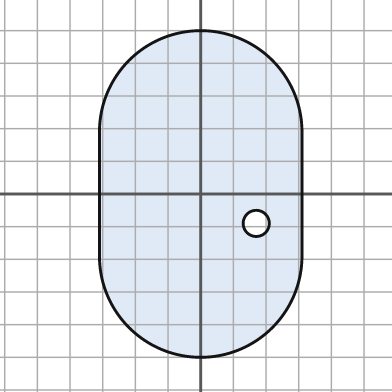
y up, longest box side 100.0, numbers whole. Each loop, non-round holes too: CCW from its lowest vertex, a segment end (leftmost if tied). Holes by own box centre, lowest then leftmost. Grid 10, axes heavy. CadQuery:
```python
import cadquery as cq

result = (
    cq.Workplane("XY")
    .moveTo(-31.0, -19.0)
    .threePointArc((0.0, -50.0), (31.0, -19.0))
    .lineTo(31.0, 19.0)
    .threePointArc((0.0, 50.0), (-31.0, 19.0))
    .close()
    .moveTo(17.0, -9.0)
    .circle(4.0)
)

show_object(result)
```